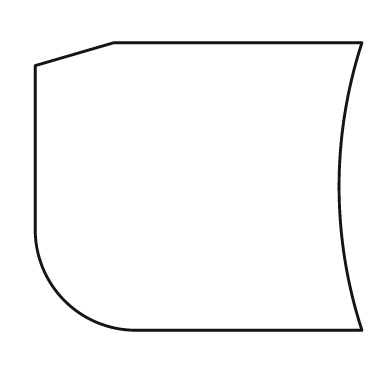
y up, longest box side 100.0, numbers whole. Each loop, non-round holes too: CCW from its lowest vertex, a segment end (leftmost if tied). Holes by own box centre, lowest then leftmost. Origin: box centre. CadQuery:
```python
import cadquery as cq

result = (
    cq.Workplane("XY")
    .moveTo(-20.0, -44.0)
    .lineTo(50.0, -44.0)
    .threePointArc((43.0, 0.0), (50.0, 44.0))
    .lineTo(-26.0, 44.0)
    .lineTo(-50.0, 37.0)
    .lineTo(-50.0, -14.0)
    .threePointArc((-41.0, -35.0), (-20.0, -44.0))
    .close()
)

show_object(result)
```